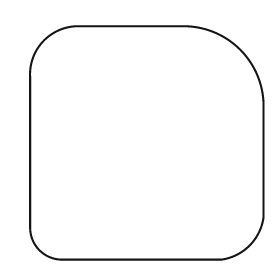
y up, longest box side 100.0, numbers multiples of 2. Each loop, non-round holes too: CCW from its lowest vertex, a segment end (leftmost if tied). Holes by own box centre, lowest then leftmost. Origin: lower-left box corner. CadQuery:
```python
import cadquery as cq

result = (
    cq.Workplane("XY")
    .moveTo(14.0, 0.0)
    .lineTo(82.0, 0.0)
    .threePointArc((94.0, 6.0), (100.0, 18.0))
    .lineTo(100.0, 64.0)
    .threePointArc((90.0, 90.0), (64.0, 100.0))
    .lineTo(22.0, 100.0)
    .threePointArc((6.0, 94.0), (0.0, 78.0))
    .lineTo(0.0, 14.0)
    .threePointArc((4.0, 4.0), (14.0, 0.0))
    .close()
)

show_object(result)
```